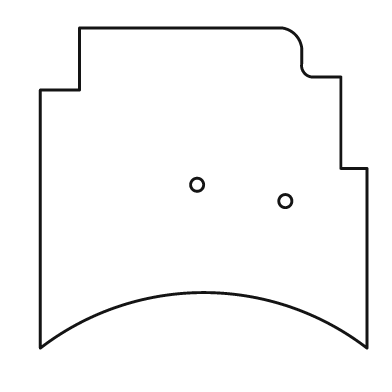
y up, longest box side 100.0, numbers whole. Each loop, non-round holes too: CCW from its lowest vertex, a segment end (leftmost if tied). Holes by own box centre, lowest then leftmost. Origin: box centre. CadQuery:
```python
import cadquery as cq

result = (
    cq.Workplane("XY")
    .moveTo(-50.0, -49.0)
    .threePointArc((0.0, -32.0), (50.0, -49.0))
    .lineTo(50.0, 6.0)
    .lineTo(42.0, 6.0)
    .lineTo(42.0, 34.0)
    .lineTo(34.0, 34.0)
    .threePointArc((31.0, 35.0), (30.0, 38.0))
    .lineTo(30.0, 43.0)
    .threePointArc((28.0, 47.0), (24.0, 49.0))
    .lineTo(-38.0, 49.0)
    .lineTo(-38.0, 30.0)
    .lineTo(-50.0, 30.0)
    .close()
    .moveTo(25.0, -4.0)
    .circle(2.0)
    .moveTo(-2.0, 1.0)
    .circle(2.0)
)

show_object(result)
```